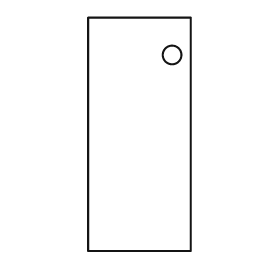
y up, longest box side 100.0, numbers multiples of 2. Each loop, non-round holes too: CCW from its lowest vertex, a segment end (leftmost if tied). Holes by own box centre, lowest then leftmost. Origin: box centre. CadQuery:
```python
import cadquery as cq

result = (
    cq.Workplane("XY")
    .moveTo(-22.0, -50.0)
    .lineTo(22.0, -50.0)
    .lineTo(22.0, 50.0)
    .lineTo(-22.0, 50.0)
    .close()
    .moveTo(14.0, 34.0)
    .circle(4.0)
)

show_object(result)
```